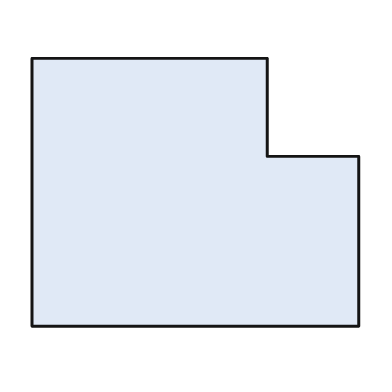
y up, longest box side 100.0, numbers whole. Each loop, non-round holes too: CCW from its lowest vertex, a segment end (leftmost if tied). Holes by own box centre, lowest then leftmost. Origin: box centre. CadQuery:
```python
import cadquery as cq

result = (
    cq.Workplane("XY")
    .moveTo(-50.0, -41.0)
    .lineTo(50.0, -41.0)
    .lineTo(50.0, 11.0)
    .lineTo(22.0, 11.0)
    .lineTo(22.0, 41.0)
    .lineTo(-50.0, 41.0)
    .close()
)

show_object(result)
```